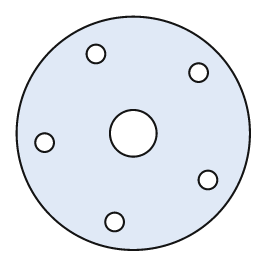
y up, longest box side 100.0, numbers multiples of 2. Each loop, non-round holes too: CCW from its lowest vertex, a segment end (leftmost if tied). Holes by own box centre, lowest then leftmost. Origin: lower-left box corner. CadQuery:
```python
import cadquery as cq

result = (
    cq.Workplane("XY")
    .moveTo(50.0, 50.0)
    .circle(50.0)
    .moveTo(42.0, 12.0)
    .circle(4.0)
    .moveTo(82.0, 30.0)
    .circle(4.0)
    .moveTo(12.0, 46.0)
    .circle(4.0)
    .moveTo(50.0, 50.0)
    .circle(10.0)
    .moveTo(78.0, 76.0)
    .circle(4.0)
    .moveTo(34.0, 84.0)
    .circle(4.0)
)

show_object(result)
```